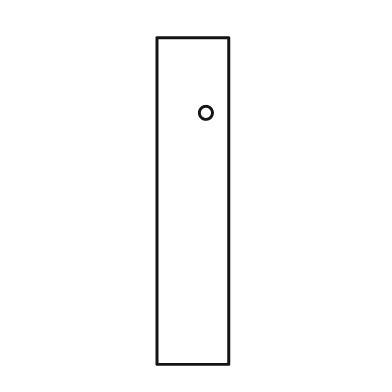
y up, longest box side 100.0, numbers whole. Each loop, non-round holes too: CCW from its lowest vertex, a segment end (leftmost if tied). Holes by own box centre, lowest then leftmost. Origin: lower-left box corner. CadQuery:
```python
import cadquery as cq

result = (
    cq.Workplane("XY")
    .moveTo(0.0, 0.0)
    .lineTo(22.0, 0.0)
    .lineTo(22.0, 100.0)
    .lineTo(0.0, 100.0)
    .close()
    .moveTo(15.0, 77.0)
    .circle(2.0)
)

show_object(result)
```